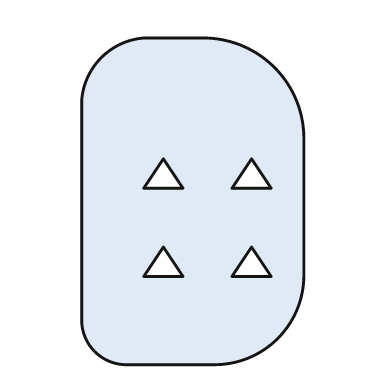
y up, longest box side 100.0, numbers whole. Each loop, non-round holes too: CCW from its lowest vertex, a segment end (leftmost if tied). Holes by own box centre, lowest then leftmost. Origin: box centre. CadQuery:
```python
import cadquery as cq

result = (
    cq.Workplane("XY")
    .moveTo(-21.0, -50.0)
    .lineTo(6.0, -50.0)
    .threePointArc((26.0, -42.0), (34.0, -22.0))
    .lineTo(34.0, 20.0)
    .threePointArc((25.0, 41.0), (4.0, 50.0))
    .lineTo(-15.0, 50.0)
    .threePointArc((-28.0, 44.0), (-34.0, 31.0))
    .lineTo(-34.0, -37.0)
    .threePointArc((-30.0, -46.0), (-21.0, -50.0))
    .close()
    .moveTo(-15.0, -23.0)
    .lineTo(-3.0, -23.0)
    .lineTo(-9.0, -14.0)
    .close()
    .moveTo(12.0, -23.0)
    .lineTo(24.0, -23.0)
    .lineTo(18.0, -14.0)
    .close()
    .moveTo(-15.0, 4.0)
    .lineTo(-3.0, 4.0)
    .lineTo(-9.0, 13.0)
    .close()
    .moveTo(12.0, 4.0)
    .lineTo(24.0, 4.0)
    .lineTo(18.0, 13.0)
    .close()
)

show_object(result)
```